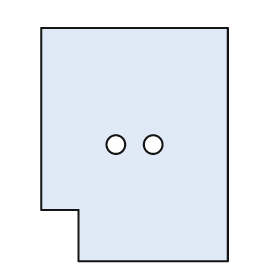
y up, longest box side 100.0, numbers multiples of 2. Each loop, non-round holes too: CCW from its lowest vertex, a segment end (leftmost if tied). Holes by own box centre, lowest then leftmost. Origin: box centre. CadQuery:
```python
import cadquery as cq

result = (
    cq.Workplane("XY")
    .moveTo(-24.0, -50.0)
    .lineTo(40.0, -50.0)
    .lineTo(40.0, 50.0)
    .lineTo(-40.0, 50.0)
    .lineTo(-40.0, -28.0)
    .lineTo(-24.0, -28.0)
    .close()
    .moveTo(-8.0, 0.0)
    .circle(4.0)
    .moveTo(8.0, 0.0)
    .circle(4.0)
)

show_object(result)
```